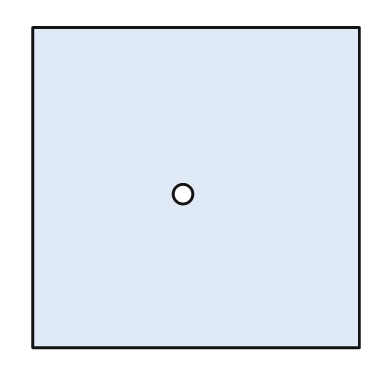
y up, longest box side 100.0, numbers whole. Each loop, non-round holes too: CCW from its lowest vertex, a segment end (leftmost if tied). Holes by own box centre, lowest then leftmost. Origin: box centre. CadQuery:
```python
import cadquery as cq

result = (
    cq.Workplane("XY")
    .moveTo(-50.0, -49.0)
    .lineTo(50.0, -49.0)
    .lineTo(50.0, 49.0)
    .lineTo(-50.0, 49.0)
    .close()
    .moveTo(-4.0, -2.0)
    .circle(3.0)
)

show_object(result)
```